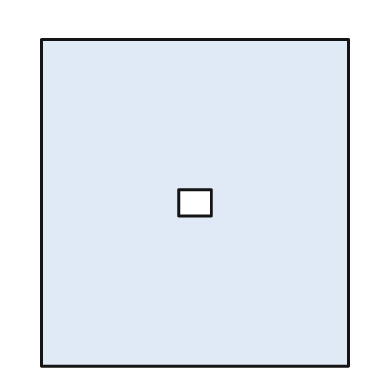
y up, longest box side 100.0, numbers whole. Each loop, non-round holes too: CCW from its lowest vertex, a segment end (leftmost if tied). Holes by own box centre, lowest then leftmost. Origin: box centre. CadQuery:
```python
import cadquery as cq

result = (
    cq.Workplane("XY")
    .moveTo(-47.0, -50.0)
    .lineTo(47.0, -50.0)
    .lineTo(47.0, 50.0)
    .lineTo(-47.0, 50.0)
    .close()
    .moveTo(-5.0, -4.0)
    .lineTo(5.0, -4.0)
    .lineTo(5.0, 4.0)
    .lineTo(-5.0, 4.0)
    .close()
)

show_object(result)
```